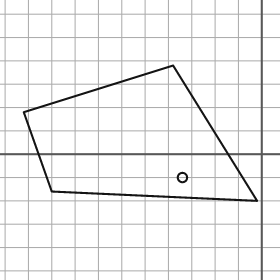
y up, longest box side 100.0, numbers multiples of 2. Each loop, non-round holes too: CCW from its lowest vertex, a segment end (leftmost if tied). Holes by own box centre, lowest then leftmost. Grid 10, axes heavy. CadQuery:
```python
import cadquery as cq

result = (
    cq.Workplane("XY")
    .moveTo(-2.0, -20.0)
    .lineTo(-38.0, 38.0)
    .lineTo(-102.0, 18.0)
    .lineTo(-90.0, -16.0)
    .close()
    .moveTo(-34.0, -10.0)
    .circle(2.0)
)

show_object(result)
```